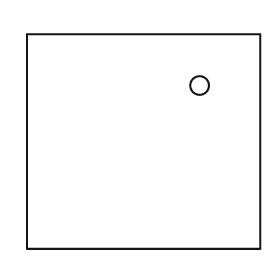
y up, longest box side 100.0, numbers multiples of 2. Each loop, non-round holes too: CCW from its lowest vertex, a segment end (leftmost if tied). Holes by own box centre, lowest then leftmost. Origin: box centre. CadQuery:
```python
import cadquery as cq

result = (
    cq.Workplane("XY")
    .moveTo(-50.0, -46.0)
    .lineTo(50.0, -46.0)
    .lineTo(50.0, 46.0)
    .lineTo(-50.0, 46.0)
    .close()
    .moveTo(24.0, 24.0)
    .circle(4.0)
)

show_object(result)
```